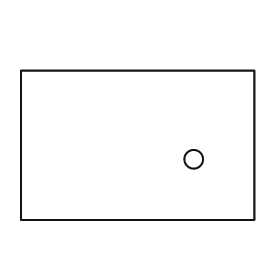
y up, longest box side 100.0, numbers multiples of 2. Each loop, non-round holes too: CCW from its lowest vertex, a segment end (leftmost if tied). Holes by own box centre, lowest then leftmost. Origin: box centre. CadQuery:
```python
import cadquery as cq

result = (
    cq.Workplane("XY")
    .moveTo(-50.0, -32.0)
    .lineTo(50.0, -32.0)
    .lineTo(50.0, 32.0)
    .lineTo(-50.0, 32.0)
    .close()
    .moveTo(24.0, -6.0)
    .circle(4.0)
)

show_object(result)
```